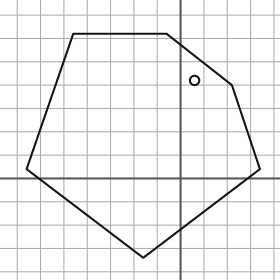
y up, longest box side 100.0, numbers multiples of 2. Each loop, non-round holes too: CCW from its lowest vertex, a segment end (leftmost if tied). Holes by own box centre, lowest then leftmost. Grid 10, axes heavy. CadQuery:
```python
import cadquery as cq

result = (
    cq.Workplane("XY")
    .moveTo(-16.0, -34.0)
    .lineTo(34.0, 4.0)
    .lineTo(22.0, 40.0)
    .lineTo(-6.0, 62.0)
    .lineTo(-46.0, 62.0)
    .lineTo(-66.0, 4.0)
    .close()
    .moveTo(6.0, 42.0)
    .circle(2.0)
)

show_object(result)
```